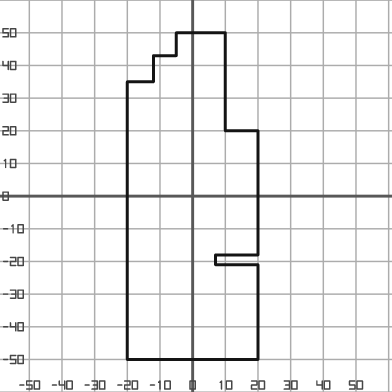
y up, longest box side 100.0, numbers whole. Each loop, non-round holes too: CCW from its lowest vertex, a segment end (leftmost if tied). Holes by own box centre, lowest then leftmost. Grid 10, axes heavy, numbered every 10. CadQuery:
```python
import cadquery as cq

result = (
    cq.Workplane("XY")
    .moveTo(-20.0, -50.0)
    .lineTo(20.0, -50.0)
    .lineTo(20.0, -21.0)
    .lineTo(7.0, -21.0)
    .lineTo(7.0, -18.0)
    .lineTo(20.0, -18.0)
    .lineTo(20.0, 20.0)
    .lineTo(10.0, 20.0)
    .lineTo(10.0, 50.0)
    .lineTo(-5.0, 50.0)
    .lineTo(-5.0, 43.0)
    .lineTo(-12.0, 43.0)
    .lineTo(-12.0, 35.0)
    .lineTo(-20.0, 35.0)
    .close()
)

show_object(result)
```